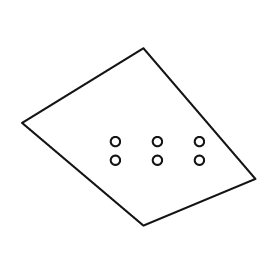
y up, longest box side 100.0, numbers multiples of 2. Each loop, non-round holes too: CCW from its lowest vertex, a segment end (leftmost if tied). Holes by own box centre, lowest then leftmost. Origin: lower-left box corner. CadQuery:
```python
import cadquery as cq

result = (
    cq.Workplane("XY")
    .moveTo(52.0, 0.0)
    .lineTo(100.0, 20.0)
    .lineTo(52.0, 76.0)
    .lineTo(0.0, 44.0)
    .close()
    .moveTo(40.0, 28.0)
    .circle(2.0)
    .moveTo(58.0, 28.0)
    .circle(2.0)
    .moveTo(76.0, 28.0)
    .circle(2.0)
    .moveTo(40.0, 36.0)
    .circle(2.0)
    .moveTo(58.0, 36.0)
    .circle(2.0)
    .moveTo(76.0, 36.0)
    .circle(2.0)
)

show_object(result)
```